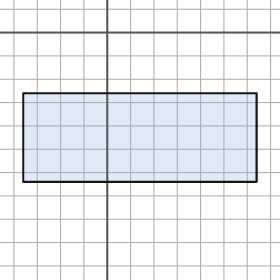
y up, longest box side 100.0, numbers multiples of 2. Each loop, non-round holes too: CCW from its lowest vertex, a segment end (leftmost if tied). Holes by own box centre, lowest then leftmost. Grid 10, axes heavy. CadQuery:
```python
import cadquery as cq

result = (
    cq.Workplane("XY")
    .moveTo(-36.0, -64.0)
    .lineTo(64.0, -64.0)
    .lineTo(64.0, -26.0)
    .lineTo(-36.0, -26.0)
    .close()
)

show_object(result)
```